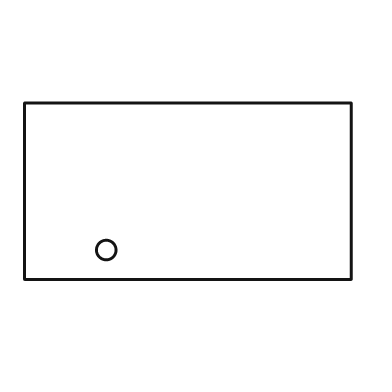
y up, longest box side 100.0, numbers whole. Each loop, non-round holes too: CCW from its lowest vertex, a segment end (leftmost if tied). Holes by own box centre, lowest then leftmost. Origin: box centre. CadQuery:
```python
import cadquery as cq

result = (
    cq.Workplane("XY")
    .moveTo(-50.0, -27.0)
    .lineTo(50.0, -27.0)
    .lineTo(50.0, 27.0)
    .lineTo(-50.0, 27.0)
    .close()
    .moveTo(-25.0, -18.0)
    .circle(3.0)
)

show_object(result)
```